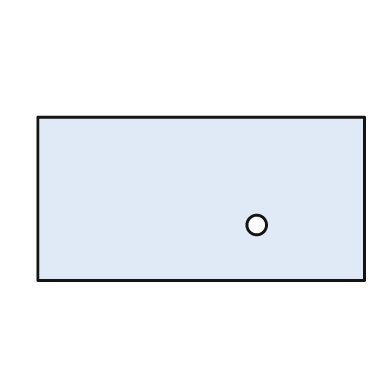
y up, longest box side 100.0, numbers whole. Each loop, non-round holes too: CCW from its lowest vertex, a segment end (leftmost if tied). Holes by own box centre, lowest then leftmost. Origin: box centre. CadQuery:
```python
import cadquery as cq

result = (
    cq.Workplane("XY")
    .moveTo(-50.0, -25.0)
    .lineTo(50.0, -25.0)
    .lineTo(50.0, 25.0)
    .lineTo(-50.0, 25.0)
    .close()
    .moveTo(17.0, -8.0)
    .circle(3.0)
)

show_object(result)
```